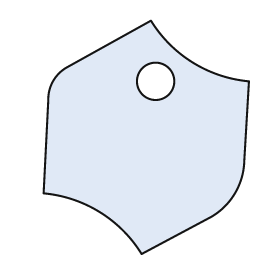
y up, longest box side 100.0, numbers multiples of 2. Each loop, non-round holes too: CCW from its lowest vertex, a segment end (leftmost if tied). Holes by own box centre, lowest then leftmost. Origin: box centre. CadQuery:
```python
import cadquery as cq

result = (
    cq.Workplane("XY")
    .moveTo(-2.0, -50.0)
    .lineTo(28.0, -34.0)
    .threePointArc((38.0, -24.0), (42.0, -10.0))
    .lineTo(44.0, 24.0)
    .threePointArc((20.0, 32.0), (2.0, 50.0))
    .lineTo(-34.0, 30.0)
    .threePointArc((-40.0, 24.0), (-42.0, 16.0))
    .lineTo(-44.0, -24.0)
    .threePointArc((-20.0, -32.0), (-2.0, -50.0))
    .close()
    .moveTo(4.0, 24.0)
    .circle(8.0)
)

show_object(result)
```